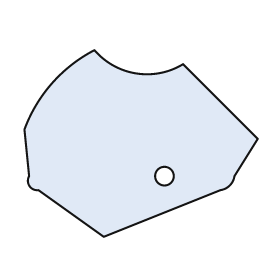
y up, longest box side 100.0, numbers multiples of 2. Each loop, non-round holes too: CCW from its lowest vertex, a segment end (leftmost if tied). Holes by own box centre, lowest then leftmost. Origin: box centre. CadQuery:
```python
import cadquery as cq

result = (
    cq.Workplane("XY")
    .moveTo(-16.0, -40.0)
    .lineTo(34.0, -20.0)
    .threePointArc((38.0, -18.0), (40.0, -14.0))
    .lineTo(50.0, 2.0)
    .lineTo(18.0, 34.0)
    .threePointArc((-2.0, 30.0), (-20.0, 40.0))
    .threePointArc((-38.0, 26.0), (-50.0, 6.0))
    .lineTo(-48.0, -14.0)
    .threePointArc((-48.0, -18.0), (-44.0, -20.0))
    .close()
    .moveTo(10.0, -14.0)
    .circle(4.0)
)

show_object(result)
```